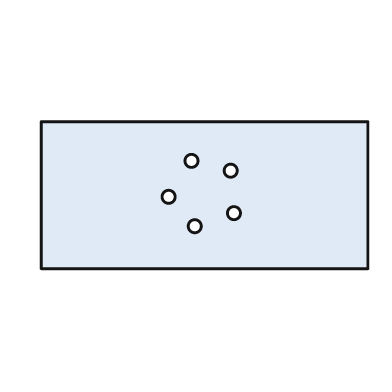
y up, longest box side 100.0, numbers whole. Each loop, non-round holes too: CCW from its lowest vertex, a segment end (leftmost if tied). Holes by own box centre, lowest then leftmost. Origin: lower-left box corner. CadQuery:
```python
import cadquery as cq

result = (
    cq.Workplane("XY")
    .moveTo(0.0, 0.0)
    .lineTo(100.0, 0.0)
    .lineTo(100.0, 45.0)
    .lineTo(0.0, 45.0)
    .close()
    .moveTo(47.0, 13.0)
    .circle(2.0)
    .moveTo(59.0, 17.0)
    .circle(2.0)
    .moveTo(39.0, 22.0)
    .circle(2.0)
    .moveTo(58.0, 30.0)
    .circle(2.0)
    .moveTo(46.0, 33.0)
    .circle(2.0)
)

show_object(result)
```